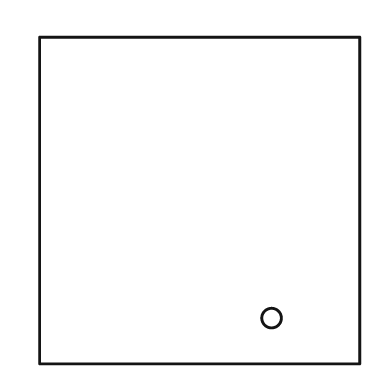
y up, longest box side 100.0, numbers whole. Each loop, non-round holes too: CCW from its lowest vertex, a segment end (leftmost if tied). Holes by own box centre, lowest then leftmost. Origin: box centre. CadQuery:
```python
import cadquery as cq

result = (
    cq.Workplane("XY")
    .moveTo(-49.0, -50.0)
    .lineTo(49.0, -50.0)
    .lineTo(49.0, 50.0)
    .lineTo(-49.0, 50.0)
    .close()
    .moveTo(22.0, -36.0)
    .circle(3.0)
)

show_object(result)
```